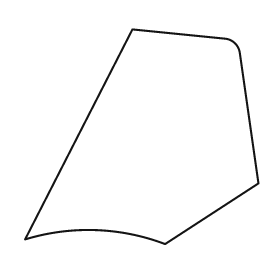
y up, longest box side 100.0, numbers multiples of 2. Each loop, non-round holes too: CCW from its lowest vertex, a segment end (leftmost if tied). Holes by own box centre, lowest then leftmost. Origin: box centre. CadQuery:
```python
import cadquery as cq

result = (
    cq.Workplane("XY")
    .moveTo(10.0, -46.0)
    .lineTo(50.0, -20.0)
    .lineTo(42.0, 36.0)
    .threePointArc((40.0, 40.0), (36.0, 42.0))
    .lineTo(-4.0, 46.0)
    .lineTo(-50.0, -44.0)
    .threePointArc((-20.0, -40.0), (10.0, -46.0))
    .close()
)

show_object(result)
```